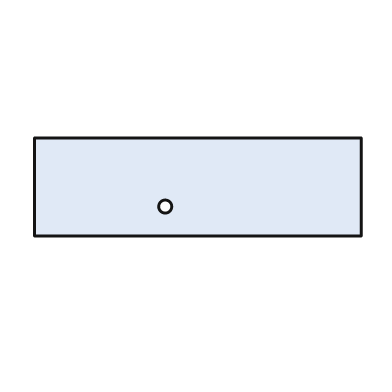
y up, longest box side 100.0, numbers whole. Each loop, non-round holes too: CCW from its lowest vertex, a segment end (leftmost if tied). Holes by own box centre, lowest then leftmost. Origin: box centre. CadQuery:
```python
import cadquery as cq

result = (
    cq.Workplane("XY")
    .moveTo(-50.0, -15.0)
    .lineTo(50.0, -15.0)
    .lineTo(50.0, 15.0)
    .lineTo(-50.0, 15.0)
    .close()
    .moveTo(-10.0, -6.0)
    .circle(2.0)
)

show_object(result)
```